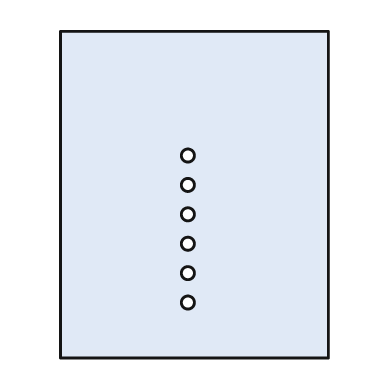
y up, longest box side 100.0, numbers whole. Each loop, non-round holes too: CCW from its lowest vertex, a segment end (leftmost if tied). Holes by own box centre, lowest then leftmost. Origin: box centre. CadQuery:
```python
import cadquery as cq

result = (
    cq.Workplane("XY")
    .moveTo(-41.0, -50.0)
    .lineTo(41.0, -50.0)
    .lineTo(41.0, 50.0)
    .lineTo(-41.0, 50.0)
    .close()
    .moveTo(-2.0, -33.0)
    .circle(2.0)
    .moveTo(-2.0, -24.0)
    .circle(2.0)
    .moveTo(-2.0, -15.0)
    .circle(2.0)
    .moveTo(-2.0, -6.0)
    .circle(2.0)
    .moveTo(-2.0, 3.0)
    .circle(2.0)
    .moveTo(-2.0, 12.0)
    .circle(2.0)
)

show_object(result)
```